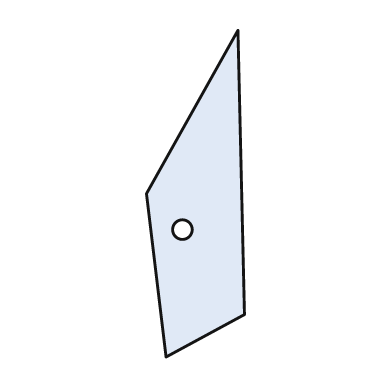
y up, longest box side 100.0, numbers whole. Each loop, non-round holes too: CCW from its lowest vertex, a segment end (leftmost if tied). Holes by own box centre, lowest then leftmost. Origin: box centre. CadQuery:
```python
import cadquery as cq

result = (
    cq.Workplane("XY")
    .moveTo(-9.0, -50.0)
    .lineTo(15.0, -37.0)
    .lineTo(13.0, 50.0)
    .lineTo(-15.0, 0.0)
    .close()
    .moveTo(-4.0, -11.0)
    .circle(3.0)
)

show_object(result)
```